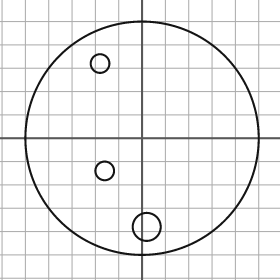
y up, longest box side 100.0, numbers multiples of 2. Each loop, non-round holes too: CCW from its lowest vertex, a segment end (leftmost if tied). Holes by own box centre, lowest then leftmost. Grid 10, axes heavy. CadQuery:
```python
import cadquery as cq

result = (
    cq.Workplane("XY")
    .moveTo(0.0, 0.0)
    .circle(50.0)
    .moveTo(2.0, -38.0)
    .circle(6.0)
    .moveTo(-16.0, -14.0)
    .circle(4.0)
    .moveTo(-18.0, 32.0)
    .circle(4.0)
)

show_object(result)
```